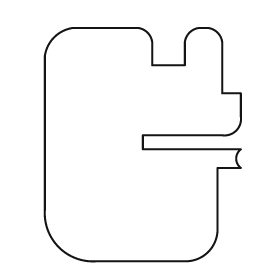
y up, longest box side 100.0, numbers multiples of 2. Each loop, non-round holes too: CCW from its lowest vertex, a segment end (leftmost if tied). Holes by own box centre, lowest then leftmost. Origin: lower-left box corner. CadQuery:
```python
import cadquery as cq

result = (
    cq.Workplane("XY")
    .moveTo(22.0, 0.0)
    .lineTo(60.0, 0.0)
    .threePointArc((70.0, 4.0), (74.0, 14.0))
    .lineTo(74.0, 40.0)
    .lineTo(84.0, 40.0)
    .threePointArc((82.0, 44.0), (84.0, 48.0))
    .lineTo(42.0, 48.0)
    .lineTo(42.0, 54.0)
    .lineTo(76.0, 54.0)
    .threePointArc((82.0, 56.0), (84.0, 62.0))
    .lineTo(84.0, 72.0)
    .lineTo(76.0, 72.0)
    .lineTo(76.0, 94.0)
    .threePointArc((74.0, 98.0), (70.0, 100.0))
    .lineTo(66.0, 100.0)
    .threePointArc((62.0, 98.0), (60.0, 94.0))
    .lineTo(60.0, 84.0)
    .lineTo(46.0, 84.0)
    .lineTo(46.0, 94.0)
    .threePointArc((44.0, 98.0), (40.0, 100.0))
    .lineTo(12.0, 100.0)
    .threePointArc((4.0, 96.0), (0.0, 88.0))
    .lineTo(0.0, 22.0)
    .threePointArc((6.0, 6.0), (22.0, 0.0))
    .close()
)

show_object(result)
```